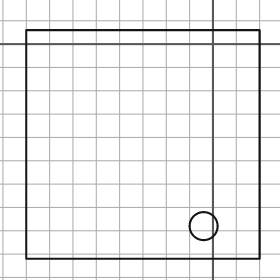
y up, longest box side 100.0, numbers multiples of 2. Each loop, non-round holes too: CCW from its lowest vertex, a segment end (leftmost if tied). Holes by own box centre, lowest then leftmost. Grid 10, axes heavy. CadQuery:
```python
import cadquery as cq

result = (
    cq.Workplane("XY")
    .moveTo(-80.0, -92.0)
    .lineTo(20.0, -92.0)
    .lineTo(20.0, 6.0)
    .lineTo(-80.0, 6.0)
    .close()
    .moveTo(-4.0, -78.0)
    .circle(6.0)
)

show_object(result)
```